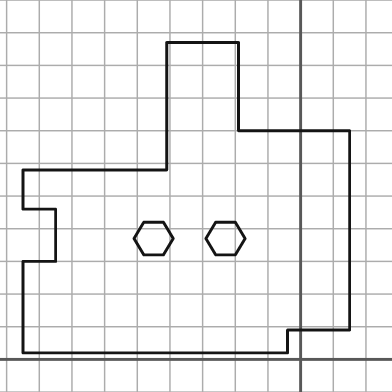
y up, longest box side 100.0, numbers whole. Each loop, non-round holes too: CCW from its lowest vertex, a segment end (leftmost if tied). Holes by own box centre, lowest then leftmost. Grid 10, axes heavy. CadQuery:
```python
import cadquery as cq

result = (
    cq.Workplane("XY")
    .moveTo(-85.0, 2.0)
    .lineTo(-4.0, 2.0)
    .lineTo(-4.0, 9.0)
    .lineTo(15.0, 9.0)
    .lineTo(15.0, 70.0)
    .lineTo(-19.0, 70.0)
    .lineTo(-19.0, 97.0)
    .lineTo(-41.0, 97.0)
    .lineTo(-41.0, 58.0)
    .lineTo(-85.0, 58.0)
    .lineTo(-85.0, 46.0)
    .lineTo(-75.0, 46.0)
    .lineTo(-75.0, 30.0)
    .lineTo(-85.0, 30.0)
    .close()
    .moveTo(-48.0, 32.0)
    .lineTo(-42.0, 32.0)
    .lineTo(-39.0, 37.0)
    .lineTo(-42.0, 42.0)
    .lineTo(-48.0, 42.0)
    .lineTo(-51.0, 37.0)
    .close()
    .moveTo(-26.0, 32.0)
    .lineTo(-20.0, 32.0)
    .lineTo(-17.0, 37.0)
    .lineTo(-20.0, 42.0)
    .lineTo(-26.0, 42.0)
    .lineTo(-29.0, 37.0)
    .close()
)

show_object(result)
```